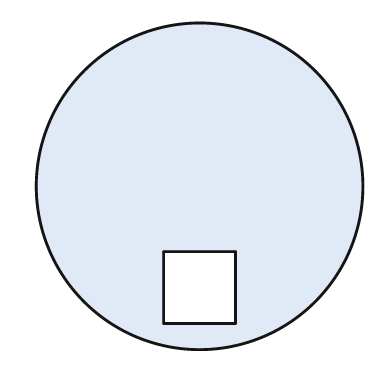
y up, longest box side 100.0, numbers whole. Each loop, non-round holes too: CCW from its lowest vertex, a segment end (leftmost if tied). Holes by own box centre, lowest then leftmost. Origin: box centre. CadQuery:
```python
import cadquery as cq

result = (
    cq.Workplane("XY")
    .moveTo(0.0, 0.0)
    .circle(50.0)
    .moveTo(-11.0, -42.0)
    .lineTo(11.0, -42.0)
    .lineTo(11.0, -20.0)
    .lineTo(-11.0, -20.0)
    .close()
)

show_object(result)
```